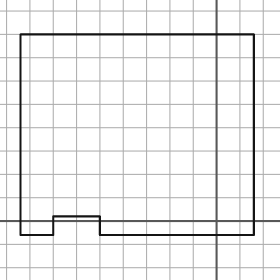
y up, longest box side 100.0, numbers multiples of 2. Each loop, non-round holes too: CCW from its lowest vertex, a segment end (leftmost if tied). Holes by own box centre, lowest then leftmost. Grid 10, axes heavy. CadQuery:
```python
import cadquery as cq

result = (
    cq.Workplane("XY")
    .moveTo(-84.0, -6.0)
    .lineTo(-70.0, -6.0)
    .lineTo(-70.0, 2.0)
    .lineTo(-50.0, 2.0)
    .lineTo(-50.0, -6.0)
    .lineTo(16.0, -6.0)
    .lineTo(16.0, 80.0)
    .lineTo(-84.0, 80.0)
    .close()
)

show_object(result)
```